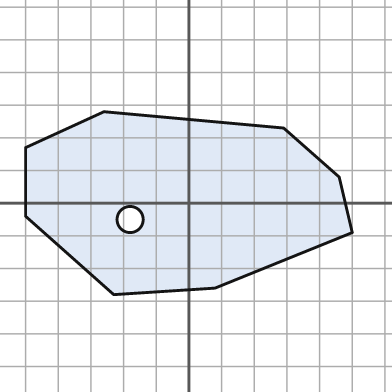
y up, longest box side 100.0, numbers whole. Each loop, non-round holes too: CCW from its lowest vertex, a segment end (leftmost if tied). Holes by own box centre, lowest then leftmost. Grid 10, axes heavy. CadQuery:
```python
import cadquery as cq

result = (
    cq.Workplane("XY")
    .moveTo(-23.0, -28.0)
    .lineTo(8.0, -26.0)
    .lineTo(50.0, -9.0)
    .lineTo(46.0, 8.0)
    .lineTo(29.0, 23.0)
    .lineTo(-26.0, 28.0)
    .lineTo(-50.0, 17.0)
    .lineTo(-50.0, -4.0)
    .close()
    .moveTo(-18.0, -5.0)
    .circle(4.0)
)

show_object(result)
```